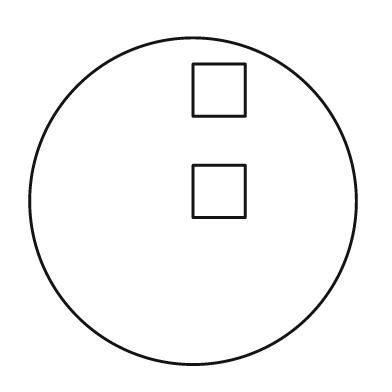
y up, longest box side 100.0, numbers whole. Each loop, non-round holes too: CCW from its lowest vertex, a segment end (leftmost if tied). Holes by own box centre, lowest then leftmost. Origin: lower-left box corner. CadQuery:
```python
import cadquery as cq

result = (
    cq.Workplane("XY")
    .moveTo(50.0, 50.0)
    .circle(50.0)
    .moveTo(50.0, 45.0)
    .lineTo(66.0, 45.0)
    .lineTo(66.0, 61.0)
    .lineTo(50.0, 61.0)
    .close()
    .moveTo(50.0, 76.0)
    .lineTo(66.0, 76.0)
    .lineTo(66.0, 92.0)
    .lineTo(50.0, 92.0)
    .close()
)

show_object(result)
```